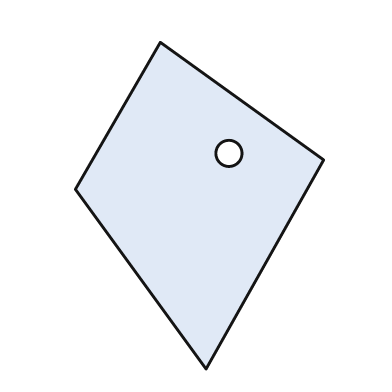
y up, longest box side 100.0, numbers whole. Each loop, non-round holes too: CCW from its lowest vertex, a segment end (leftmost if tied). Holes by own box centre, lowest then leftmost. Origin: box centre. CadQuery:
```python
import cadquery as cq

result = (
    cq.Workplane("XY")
    .moveTo(2.0, -50.0)
    .lineTo(38.0, 14.0)
    .lineTo(-12.0, 50.0)
    .lineTo(-38.0, 5.0)
    .close()
    .moveTo(9.0, 16.0)
    .circle(4.0)
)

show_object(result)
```